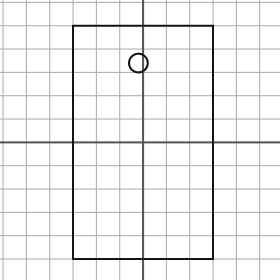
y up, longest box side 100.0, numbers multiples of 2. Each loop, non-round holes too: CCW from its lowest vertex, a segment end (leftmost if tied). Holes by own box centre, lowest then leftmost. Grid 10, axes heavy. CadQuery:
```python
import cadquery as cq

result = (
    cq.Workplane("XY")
    .moveTo(-30.0, -50.0)
    .lineTo(30.0, -50.0)
    .lineTo(30.0, 50.0)
    .lineTo(-30.0, 50.0)
    .close()
    .moveTo(-2.0, 34.0)
    .circle(4.0)
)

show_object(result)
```